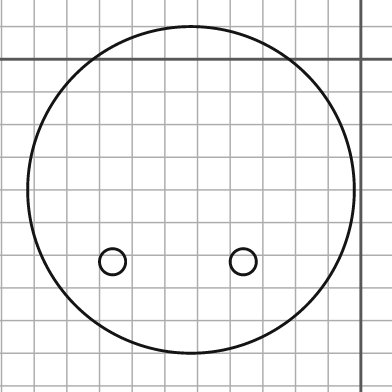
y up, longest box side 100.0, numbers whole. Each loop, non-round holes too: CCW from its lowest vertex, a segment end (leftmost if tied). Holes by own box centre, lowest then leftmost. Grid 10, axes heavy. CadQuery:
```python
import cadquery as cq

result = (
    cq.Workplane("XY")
    .moveTo(-52.0, -40.0)
    .circle(50.0)
    .moveTo(-76.0, -62.0)
    .circle(4.0)
    .moveTo(-36.0, -62.0)
    .circle(4.0)
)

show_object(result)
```